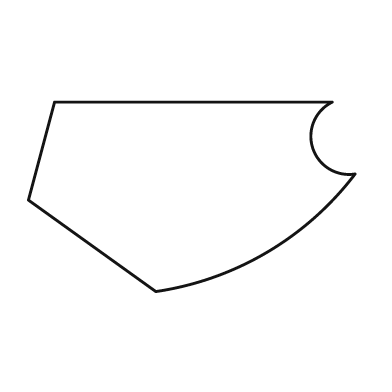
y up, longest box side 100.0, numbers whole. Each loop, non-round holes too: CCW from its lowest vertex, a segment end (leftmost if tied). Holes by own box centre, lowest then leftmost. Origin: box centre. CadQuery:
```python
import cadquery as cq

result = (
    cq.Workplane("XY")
    .moveTo(-11.0, -29.0)
    .threePointArc((23.0, -17.0), (50.0, 7.0))
    .threePointArc((37.0, 15.0), (43.0, 29.0))
    .lineTo(-42.0, 29.0)
    .lineTo(-50.0, -1.0)
    .close()
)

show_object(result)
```